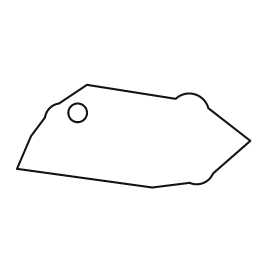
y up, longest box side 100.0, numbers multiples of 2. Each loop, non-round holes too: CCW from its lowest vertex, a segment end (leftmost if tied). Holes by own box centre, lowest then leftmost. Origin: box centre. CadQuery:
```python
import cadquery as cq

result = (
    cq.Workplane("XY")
    .moveTo(8.0, -22.0)
    .lineTo(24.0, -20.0)
    .threePointArc((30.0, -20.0), (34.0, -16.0))
    .lineTo(50.0, -2.0)
    .lineTo(32.0, 12.0)
    .threePointArc((26.0, 18.0), (18.0, 16.0))
    .lineTo(-20.0, 22.0)
    .lineTo(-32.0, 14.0)
    .threePointArc((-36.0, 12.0), (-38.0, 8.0))
    .lineTo(-44.0, 0.0)
    .lineTo(-50.0, -14.0)
    .close()
    .moveTo(-24.0, 10.0)
    .circle(4.0)
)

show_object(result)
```